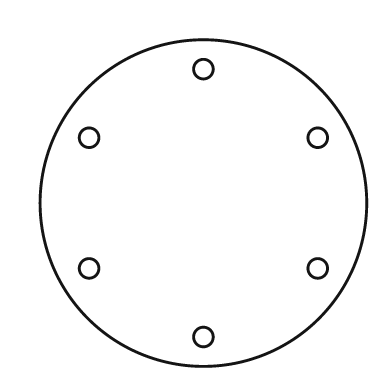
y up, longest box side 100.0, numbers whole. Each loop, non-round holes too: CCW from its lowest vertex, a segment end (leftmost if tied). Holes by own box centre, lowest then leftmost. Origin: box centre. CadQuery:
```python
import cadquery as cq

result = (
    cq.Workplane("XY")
    .moveTo(0.0, 0.0)
    .circle(50.0)
    .moveTo(0.0, -41.0)
    .circle(3.0)
    .moveTo(-35.0, -20.0)
    .circle(3.0)
    .moveTo(35.0, -20.0)
    .circle(3.0)
    .moveTo(-35.0, 20.0)
    .circle(3.0)
    .moveTo(35.0, 20.0)
    .circle(3.0)
    .moveTo(0.0, 41.0)
    .circle(3.0)
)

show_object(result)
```